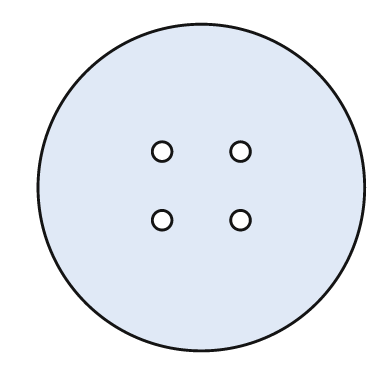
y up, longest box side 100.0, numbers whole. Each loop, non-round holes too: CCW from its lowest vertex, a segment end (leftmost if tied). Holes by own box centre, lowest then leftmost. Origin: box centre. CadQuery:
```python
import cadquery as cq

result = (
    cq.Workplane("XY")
    .moveTo(0.0, 0.0)
    .circle(50.0)
    .moveTo(-12.0, -10.0)
    .circle(3.0)
    .moveTo(12.0, -10.0)
    .circle(3.0)
    .moveTo(-12.0, 11.0)
    .circle(3.0)
    .moveTo(12.0, 11.0)
    .circle(3.0)
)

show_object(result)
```